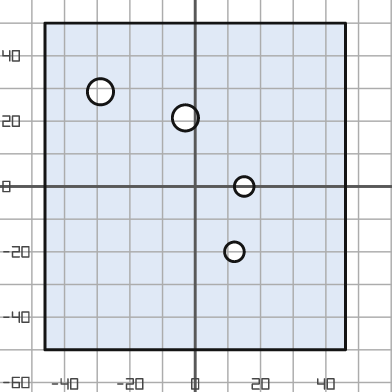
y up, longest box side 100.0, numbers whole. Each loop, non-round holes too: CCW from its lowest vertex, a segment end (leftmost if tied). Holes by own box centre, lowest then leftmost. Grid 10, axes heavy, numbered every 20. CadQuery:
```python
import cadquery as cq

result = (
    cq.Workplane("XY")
    .moveTo(-46.0, -50.0)
    .lineTo(46.0, -50.0)
    .lineTo(46.0, 50.0)
    .lineTo(-46.0, 50.0)
    .close()
    .moveTo(12.0, -20.0)
    .circle(3.0)
    .moveTo(15.0, 0.0)
    .circle(3.0)
    .moveTo(-3.0, 21.0)
    .circle(4.0)
    .moveTo(-29.0, 29.0)
    .circle(4.0)
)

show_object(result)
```